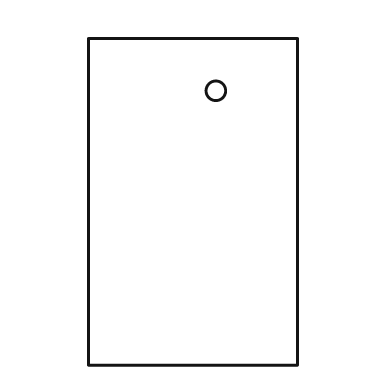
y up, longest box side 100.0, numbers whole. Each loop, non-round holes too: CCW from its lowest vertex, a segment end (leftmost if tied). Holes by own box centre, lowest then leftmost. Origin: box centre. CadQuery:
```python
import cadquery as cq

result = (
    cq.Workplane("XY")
    .moveTo(-32.0, -50.0)
    .lineTo(32.0, -50.0)
    .lineTo(32.0, 50.0)
    .lineTo(-32.0, 50.0)
    .close()
    .moveTo(7.0, 34.0)
    .circle(3.0)
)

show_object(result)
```